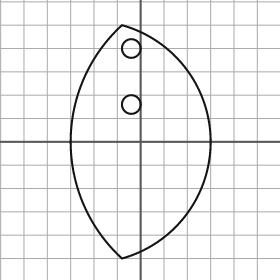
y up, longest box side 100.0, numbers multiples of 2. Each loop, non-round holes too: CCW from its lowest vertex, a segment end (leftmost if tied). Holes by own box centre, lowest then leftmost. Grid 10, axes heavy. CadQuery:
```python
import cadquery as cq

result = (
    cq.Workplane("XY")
    .moveTo(-8.0, -50.0)
    .threePointArc((30.0, 0.0), (-8.0, 50.0))
    .threePointArc((-30.0, 0.0), (-8.0, -50.0))
    .close()
    .moveTo(-4.0, 16.0)
    .circle(4.0)
    .moveTo(-4.0, 40.0)
    .circle(4.0)
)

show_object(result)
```